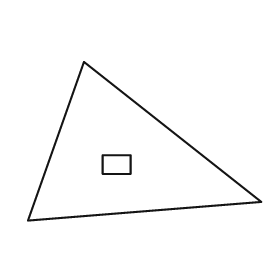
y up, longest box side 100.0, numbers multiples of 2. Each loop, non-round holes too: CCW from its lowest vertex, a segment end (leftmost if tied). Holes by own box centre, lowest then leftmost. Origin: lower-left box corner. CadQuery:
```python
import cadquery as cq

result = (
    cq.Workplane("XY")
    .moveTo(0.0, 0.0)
    .lineTo(100.0, 8.0)
    .lineTo(24.0, 68.0)
    .close()
    .moveTo(32.0, 20.0)
    .lineTo(44.0, 20.0)
    .lineTo(44.0, 28.0)
    .lineTo(32.0, 28.0)
    .close()
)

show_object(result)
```